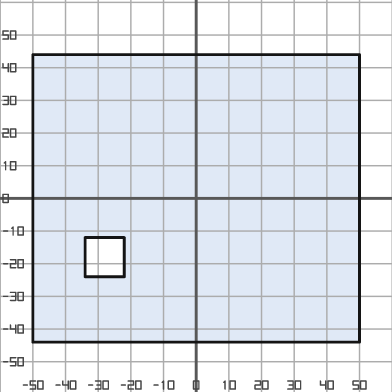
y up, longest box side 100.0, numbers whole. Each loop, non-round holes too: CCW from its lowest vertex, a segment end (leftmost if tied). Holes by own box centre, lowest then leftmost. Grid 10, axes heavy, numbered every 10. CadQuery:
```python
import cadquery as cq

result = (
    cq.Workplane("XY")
    .moveTo(-50.0, -44.0)
    .lineTo(50.0, -44.0)
    .lineTo(50.0, 44.0)
    .lineTo(-50.0, 44.0)
    .close()
    .moveTo(-34.0, -24.0)
    .lineTo(-22.0, -24.0)
    .lineTo(-22.0, -12.0)
    .lineTo(-34.0, -12.0)
    .close()
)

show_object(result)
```